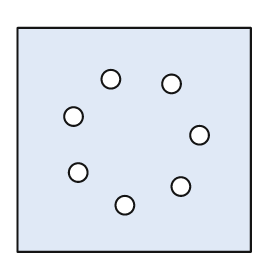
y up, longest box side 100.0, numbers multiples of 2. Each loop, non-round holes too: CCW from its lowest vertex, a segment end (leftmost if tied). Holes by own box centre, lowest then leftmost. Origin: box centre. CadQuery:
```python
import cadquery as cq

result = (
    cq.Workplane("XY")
    .moveTo(-50.0, -48.0)
    .lineTo(50.0, -48.0)
    .lineTo(50.0, 48.0)
    .lineTo(-50.0, 48.0)
    .close()
    .moveTo(-4.0, -28.0)
    .circle(4.0)
    .moveTo(20.0, -20.0)
    .circle(4.0)
    .moveTo(-24.0, -14.0)
    .circle(4.0)
    .moveTo(28.0, 2.0)
    .circle(4.0)
    .moveTo(-26.0, 10.0)
    .circle(4.0)
    .moveTo(16.0, 24.0)
    .circle(4.0)
    .moveTo(-10.0, 26.0)
    .circle(4.0)
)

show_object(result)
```